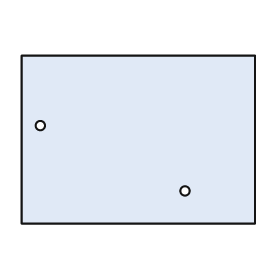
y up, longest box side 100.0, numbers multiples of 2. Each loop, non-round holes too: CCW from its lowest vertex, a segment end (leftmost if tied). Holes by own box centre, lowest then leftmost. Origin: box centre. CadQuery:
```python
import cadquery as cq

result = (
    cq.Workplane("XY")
    .moveTo(-50.0, -36.0)
    .lineTo(50.0, -36.0)
    .lineTo(50.0, 36.0)
    .lineTo(-50.0, 36.0)
    .close()
    .moveTo(20.0, -22.0)
    .circle(2.0)
    .moveTo(-42.0, 6.0)
    .circle(2.0)
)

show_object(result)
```